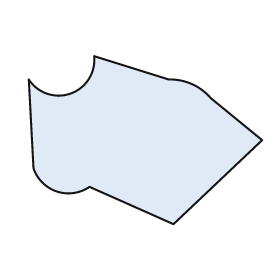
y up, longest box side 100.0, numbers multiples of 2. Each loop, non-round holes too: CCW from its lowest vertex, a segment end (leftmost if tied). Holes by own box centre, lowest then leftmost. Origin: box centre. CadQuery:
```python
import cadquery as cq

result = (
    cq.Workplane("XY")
    .moveTo(12.0, -36.0)
    .lineTo(50.0, 0.0)
    .lineTo(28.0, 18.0)
    .threePointArc((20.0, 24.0), (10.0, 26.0))
    .lineTo(-22.0, 36.0)
    .threePointArc((-32.0, 20.0), (-50.0, 26.0))
    .lineTo(-48.0, -12.0)
    .threePointArc((-38.0, -22.0), (-24.0, -20.0))
    .close()
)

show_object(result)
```